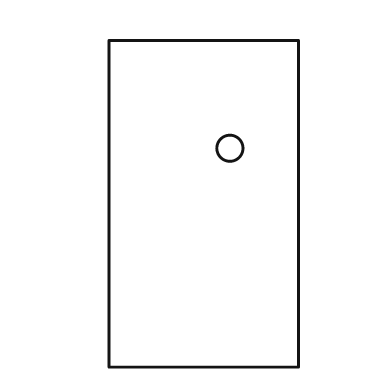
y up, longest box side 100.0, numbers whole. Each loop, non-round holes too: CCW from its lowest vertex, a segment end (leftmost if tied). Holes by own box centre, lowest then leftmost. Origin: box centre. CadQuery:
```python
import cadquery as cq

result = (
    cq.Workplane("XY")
    .moveTo(-29.0, -50.0)
    .lineTo(29.0, -50.0)
    .lineTo(29.0, 50.0)
    .lineTo(-29.0, 50.0)
    .close()
    .moveTo(8.0, 17.0)
    .circle(4.0)
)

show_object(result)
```